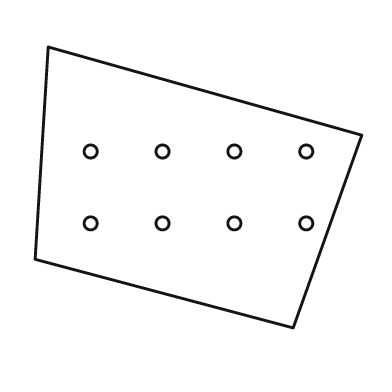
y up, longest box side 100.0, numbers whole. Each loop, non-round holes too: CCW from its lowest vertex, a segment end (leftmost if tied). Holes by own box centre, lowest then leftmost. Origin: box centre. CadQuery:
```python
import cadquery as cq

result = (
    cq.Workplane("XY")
    .moveTo(29.0, -43.0)
    .lineTo(50.0, 16.0)
    .lineTo(-46.0, 43.0)
    .lineTo(-50.0, -22.0)
    .close()
    .moveTo(-33.0, -11.0)
    .circle(2.0)
    .moveTo(-11.0, -11.0)
    .circle(2.0)
    .moveTo(11.0, -11.0)
    .circle(2.0)
    .moveTo(33.0, -11.0)
    .circle(2.0)
    .moveTo(-33.0, 11.0)
    .circle(2.0)
    .moveTo(-11.0, 11.0)
    .circle(2.0)
    .moveTo(11.0, 11.0)
    .circle(2.0)
    .moveTo(33.0, 11.0)
    .circle(2.0)
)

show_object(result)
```